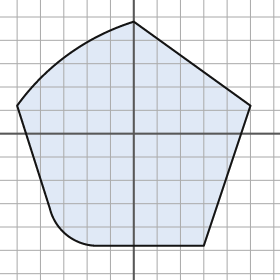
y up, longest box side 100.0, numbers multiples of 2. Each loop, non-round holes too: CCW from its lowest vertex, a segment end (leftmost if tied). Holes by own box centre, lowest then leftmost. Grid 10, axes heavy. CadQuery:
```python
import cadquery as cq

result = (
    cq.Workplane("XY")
    .moveTo(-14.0, -48.0)
    .lineTo(30.0, -48.0)
    .lineTo(50.0, 12.0)
    .lineTo(0.0, 48.0)
    .threePointArc((-28.0, 34.0), (-50.0, 12.0))
    .lineTo(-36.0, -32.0)
    .threePointArc((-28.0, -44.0), (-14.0, -48.0))
    .close()
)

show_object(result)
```